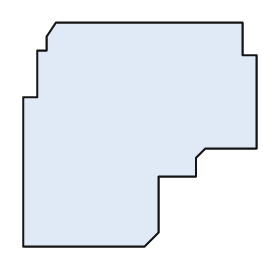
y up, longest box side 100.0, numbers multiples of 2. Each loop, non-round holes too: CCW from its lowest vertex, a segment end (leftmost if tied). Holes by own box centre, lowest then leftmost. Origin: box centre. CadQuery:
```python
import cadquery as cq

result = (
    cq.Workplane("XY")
    .moveTo(-50.0, -48.0)
    .lineTo(2.0, -48.0)
    .lineTo(8.0, -42.0)
    .lineTo(8.0, -18.0)
    .lineTo(24.0, -18.0)
    .lineTo(24.0, -10.0)
    .lineTo(28.0, -6.0)
    .lineTo(50.0, -6.0)
    .lineTo(50.0, 34.0)
    .lineTo(44.0, 34.0)
    .lineTo(44.0, 48.0)
    .lineTo(-36.0, 48.0)
    .lineTo(-40.0, 42.0)
    .lineTo(-40.0, 36.0)
    .lineTo(-44.0, 36.0)
    .lineTo(-44.0, 16.0)
    .lineTo(-50.0, 16.0)
    .close()
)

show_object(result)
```